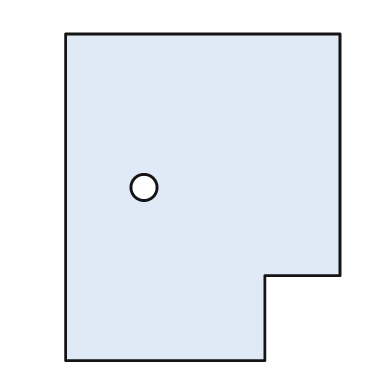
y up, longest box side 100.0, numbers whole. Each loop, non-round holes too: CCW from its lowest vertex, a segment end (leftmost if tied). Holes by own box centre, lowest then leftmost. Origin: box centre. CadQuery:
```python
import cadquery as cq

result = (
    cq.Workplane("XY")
    .moveTo(-42.0, -50.0)
    .lineTo(19.0, -50.0)
    .lineTo(19.0, -24.0)
    .lineTo(42.0, -24.0)
    .lineTo(42.0, 50.0)
    .lineTo(-42.0, 50.0)
    .close()
    .moveTo(-18.0, 3.0)
    .circle(4.0)
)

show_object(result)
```